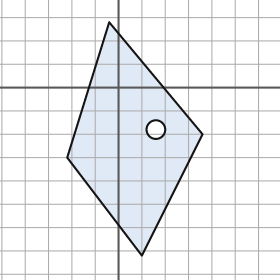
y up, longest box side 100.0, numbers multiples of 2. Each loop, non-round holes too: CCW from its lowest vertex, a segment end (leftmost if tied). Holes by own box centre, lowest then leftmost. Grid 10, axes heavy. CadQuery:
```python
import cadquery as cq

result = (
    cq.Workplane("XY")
    .moveTo(10.0, -72.0)
    .lineTo(36.0, -20.0)
    .lineTo(-4.0, 28.0)
    .lineTo(-22.0, -30.0)
    .close()
    .moveTo(16.0, -18.0)
    .circle(4.0)
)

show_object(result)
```